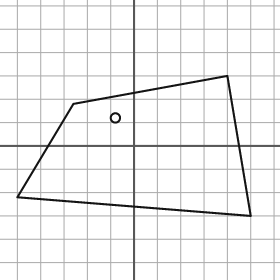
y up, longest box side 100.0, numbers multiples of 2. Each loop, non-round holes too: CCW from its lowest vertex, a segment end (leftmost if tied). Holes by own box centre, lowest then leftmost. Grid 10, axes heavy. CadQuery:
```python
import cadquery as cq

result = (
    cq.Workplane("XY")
    .moveTo(50.0, -30.0)
    .lineTo(40.0, 30.0)
    .lineTo(-26.0, 18.0)
    .lineTo(-50.0, -22.0)
    .close()
    .moveTo(-8.0, 12.0)
    .circle(2.0)
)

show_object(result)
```